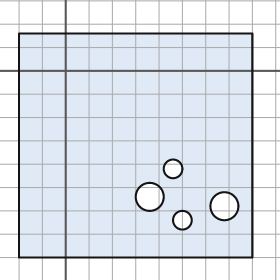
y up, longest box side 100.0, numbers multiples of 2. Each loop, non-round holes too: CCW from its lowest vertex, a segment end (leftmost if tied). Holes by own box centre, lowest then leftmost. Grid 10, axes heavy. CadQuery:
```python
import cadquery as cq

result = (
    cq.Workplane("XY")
    .moveTo(-20.0, -80.0)
    .lineTo(80.0, -80.0)
    .lineTo(80.0, 16.0)
    .lineTo(-20.0, 16.0)
    .close()
    .moveTo(50.0, -64.0)
    .circle(4.0)
    .moveTo(68.0, -58.0)
    .circle(6.0)
    .moveTo(36.0, -54.0)
    .circle(6.0)
    .moveTo(46.0, -42.0)
    .circle(4.0)
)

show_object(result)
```